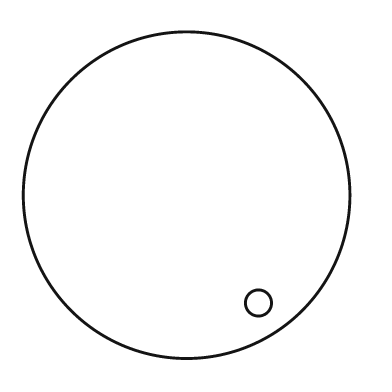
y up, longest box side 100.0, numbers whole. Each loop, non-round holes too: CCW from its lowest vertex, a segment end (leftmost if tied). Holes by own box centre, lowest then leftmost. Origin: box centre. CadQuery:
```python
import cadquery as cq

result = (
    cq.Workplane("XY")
    .moveTo(0.0, 0.0)
    .circle(50.0)
    .moveTo(22.0, -33.0)
    .circle(4.0)
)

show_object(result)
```